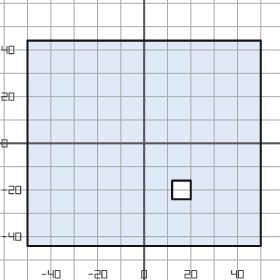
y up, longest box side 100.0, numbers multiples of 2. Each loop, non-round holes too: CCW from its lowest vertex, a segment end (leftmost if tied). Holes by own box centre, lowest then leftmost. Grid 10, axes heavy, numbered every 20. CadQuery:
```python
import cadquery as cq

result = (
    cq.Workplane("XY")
    .moveTo(-50.0, -44.0)
    .lineTo(50.0, -44.0)
    .lineTo(50.0, 44.0)
    .lineTo(-50.0, 44.0)
    .close()
    .moveTo(12.0, -24.0)
    .lineTo(20.0, -24.0)
    .lineTo(20.0, -16.0)
    .lineTo(12.0, -16.0)
    .close()
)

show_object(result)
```